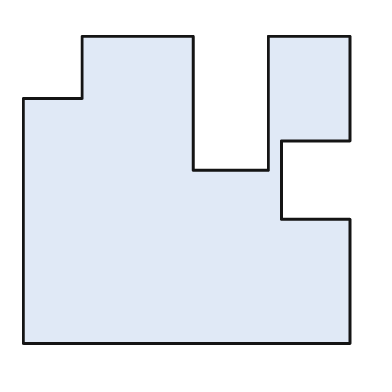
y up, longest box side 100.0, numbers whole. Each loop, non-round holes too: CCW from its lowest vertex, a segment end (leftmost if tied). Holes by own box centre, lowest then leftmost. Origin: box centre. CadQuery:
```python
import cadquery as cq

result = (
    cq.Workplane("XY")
    .moveTo(-50.0, -47.0)
    .lineTo(50.0, -47.0)
    .lineTo(50.0, -9.0)
    .lineTo(29.0, -9.0)
    .lineTo(29.0, 15.0)
    .lineTo(50.0, 15.0)
    .lineTo(50.0, 47.0)
    .lineTo(25.0, 47.0)
    .lineTo(25.0, 6.0)
    .lineTo(2.0, 6.0)
    .lineTo(2.0, 47.0)
    .lineTo(-32.0, 47.0)
    .lineTo(-32.0, 28.0)
    .lineTo(-50.0, 28.0)
    .close()
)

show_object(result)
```